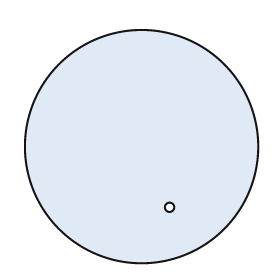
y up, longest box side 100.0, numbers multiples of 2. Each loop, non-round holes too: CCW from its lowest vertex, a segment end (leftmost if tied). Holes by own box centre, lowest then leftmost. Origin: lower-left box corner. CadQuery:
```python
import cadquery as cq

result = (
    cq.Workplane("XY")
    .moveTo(50.0, 50.0)
    .circle(50.0)
    .moveTo(62.0, 24.0)
    .circle(2.0)
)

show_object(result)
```